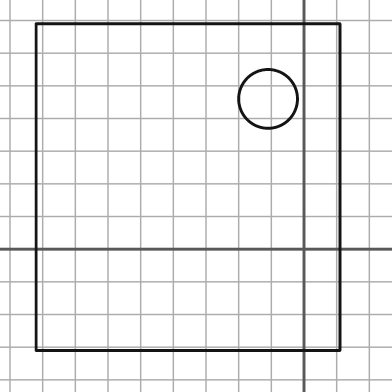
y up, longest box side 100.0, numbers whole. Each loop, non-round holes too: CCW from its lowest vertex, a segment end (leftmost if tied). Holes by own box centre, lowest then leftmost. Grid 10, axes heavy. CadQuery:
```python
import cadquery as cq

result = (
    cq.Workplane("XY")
    .moveTo(-82.0, -31.0)
    .lineTo(11.0, -31.0)
    .lineTo(11.0, 69.0)
    .lineTo(-82.0, 69.0)
    .close()
    .moveTo(-11.0, 46.0)
    .circle(9.0)
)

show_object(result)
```